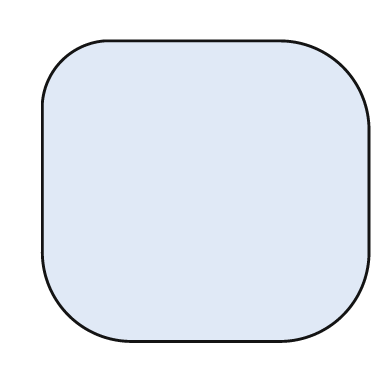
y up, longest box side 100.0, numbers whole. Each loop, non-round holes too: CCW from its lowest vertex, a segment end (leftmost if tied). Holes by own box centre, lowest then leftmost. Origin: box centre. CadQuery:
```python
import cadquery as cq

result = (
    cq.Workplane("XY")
    .moveTo(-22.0, -46.0)
    .lineTo(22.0, -46.0)
    .threePointArc((42.0, -38.0), (50.0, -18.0))
    .lineTo(50.0, 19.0)
    .threePointArc((42.0, 38.0), (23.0, 46.0))
    .lineTo(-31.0, 46.0)
    .threePointArc((-44.0, 40.0), (-50.0, 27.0))
    .lineTo(-50.0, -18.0)
    .threePointArc((-42.0, -38.0), (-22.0, -46.0))
    .close()
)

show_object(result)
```